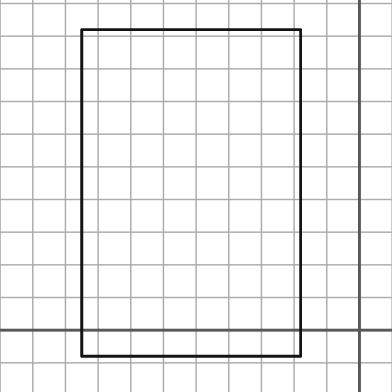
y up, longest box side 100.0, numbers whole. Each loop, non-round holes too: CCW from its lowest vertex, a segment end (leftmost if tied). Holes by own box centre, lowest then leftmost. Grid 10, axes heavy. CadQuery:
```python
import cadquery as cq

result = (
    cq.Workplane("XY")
    .moveTo(-85.0, -8.0)
    .lineTo(-18.0, -8.0)
    .lineTo(-18.0, 92.0)
    .lineTo(-85.0, 92.0)
    .close()
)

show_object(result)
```